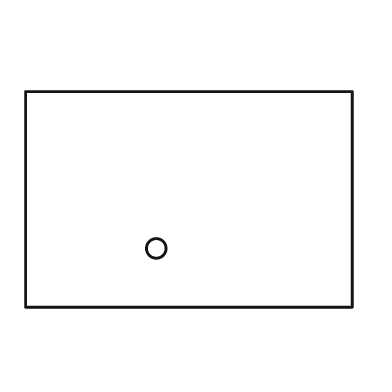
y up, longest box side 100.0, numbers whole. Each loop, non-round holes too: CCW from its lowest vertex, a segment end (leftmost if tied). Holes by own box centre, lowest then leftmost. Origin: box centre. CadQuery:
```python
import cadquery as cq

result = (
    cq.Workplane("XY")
    .moveTo(-50.0, -33.0)
    .lineTo(50.0, -33.0)
    .lineTo(50.0, 33.0)
    .lineTo(-50.0, 33.0)
    .close()
    .moveTo(-10.0, -15.0)
    .circle(3.0)
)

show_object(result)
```